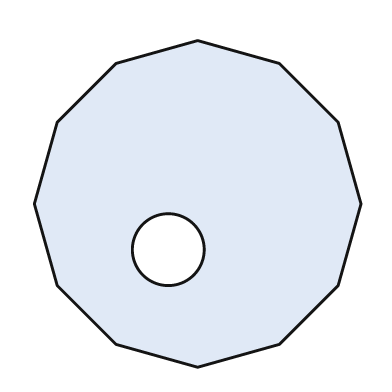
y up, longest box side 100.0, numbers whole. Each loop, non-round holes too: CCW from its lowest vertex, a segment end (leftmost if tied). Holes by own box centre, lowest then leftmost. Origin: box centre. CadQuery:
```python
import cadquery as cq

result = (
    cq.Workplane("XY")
    .moveTo(0.0, -50.0)
    .lineTo(25.0, -43.0)
    .lineTo(43.0, -25.0)
    .lineTo(50.0, 0.0)
    .lineTo(43.0, 25.0)
    .lineTo(25.0, 43.0)
    .lineTo(0.0, 50.0)
    .lineTo(-25.0, 43.0)
    .lineTo(-43.0, 25.0)
    .lineTo(-50.0, 0.0)
    .lineTo(-43.0, -25.0)
    .lineTo(-25.0, -43.0)
    .close()
    .moveTo(-9.0, -14.0)
    .circle(11.0)
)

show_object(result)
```